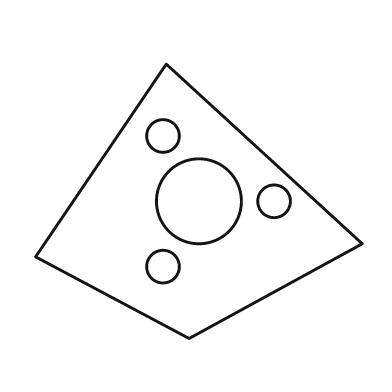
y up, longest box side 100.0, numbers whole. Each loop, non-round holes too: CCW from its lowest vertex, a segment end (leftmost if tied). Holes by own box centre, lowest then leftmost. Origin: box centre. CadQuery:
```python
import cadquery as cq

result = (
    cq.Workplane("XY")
    .moveTo(-3.0, -42.0)
    .lineTo(50.0, -13.0)
    .lineTo(-10.0, 42.0)
    .lineTo(-50.0, -17.0)
    .close()
    .moveTo(-11.0, -20.0)
    .circle(5.0)
    .moveTo(0.0, 0.0)
    .circle(13.0)
    .moveTo(23.0, 0.0)
    .circle(5.0)
    .moveTo(-11.0, 20.0)
    .circle(5.0)
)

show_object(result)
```